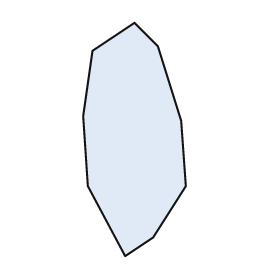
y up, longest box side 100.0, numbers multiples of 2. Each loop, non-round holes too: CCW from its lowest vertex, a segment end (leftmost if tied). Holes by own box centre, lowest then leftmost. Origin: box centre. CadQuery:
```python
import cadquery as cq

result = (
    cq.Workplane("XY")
    .moveTo(-4.0, -50.0)
    .lineTo(8.0, -42.0)
    .lineTo(22.0, -20.0)
    .lineTo(20.0, 8.0)
    .lineTo(10.0, 40.0)
    .lineTo(0.0, 50.0)
    .lineTo(-18.0, 38.0)
    .lineTo(-22.0, 10.0)
    .lineTo(-20.0, -20.0)
    .close()
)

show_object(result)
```